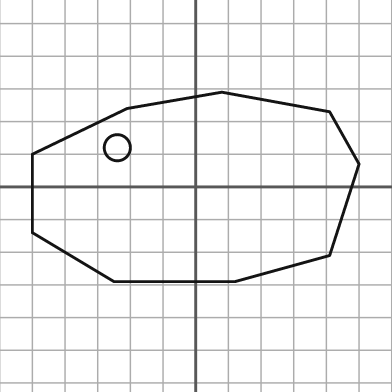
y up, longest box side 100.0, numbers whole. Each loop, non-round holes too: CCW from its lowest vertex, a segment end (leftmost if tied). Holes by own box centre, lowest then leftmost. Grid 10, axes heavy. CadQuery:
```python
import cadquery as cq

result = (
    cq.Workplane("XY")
    .moveTo(-25.0, -29.0)
    .lineTo(12.0, -29.0)
    .lineTo(41.0, -21.0)
    .lineTo(50.0, 7.0)
    .lineTo(41.0, 23.0)
    .lineTo(8.0, 29.0)
    .lineTo(-21.0, 24.0)
    .lineTo(-50.0, 10.0)
    .lineTo(-50.0, -14.0)
    .close()
    .moveTo(-24.0, 12.0)
    .circle(4.0)
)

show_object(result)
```